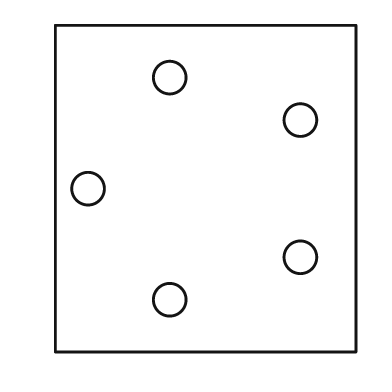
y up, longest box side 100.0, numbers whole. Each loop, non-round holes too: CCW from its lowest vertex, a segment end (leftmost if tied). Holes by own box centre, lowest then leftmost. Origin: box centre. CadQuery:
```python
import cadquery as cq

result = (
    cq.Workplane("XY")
    .moveTo(-46.0, -50.0)
    .lineTo(46.0, -50.0)
    .lineTo(46.0, 50.0)
    .lineTo(-46.0, 50.0)
    .close()
    .moveTo(-11.0, -34.0)
    .circle(5.0)
    .moveTo(29.0, -21.0)
    .circle(5.0)
    .moveTo(-36.0, 0.0)
    .circle(5.0)
    .moveTo(29.0, 21.0)
    .circle(5.0)
    .moveTo(-11.0, 34.0)
    .circle(5.0)
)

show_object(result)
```